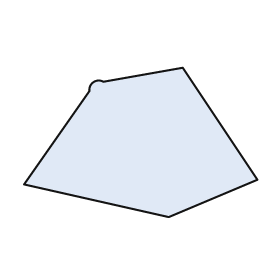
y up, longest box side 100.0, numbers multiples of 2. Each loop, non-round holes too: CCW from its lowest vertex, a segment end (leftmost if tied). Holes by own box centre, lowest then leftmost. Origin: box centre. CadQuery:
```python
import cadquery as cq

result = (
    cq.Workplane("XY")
    .moveTo(12.0, -32.0)
    .lineTo(50.0, -16.0)
    .lineTo(18.0, 32.0)
    .lineTo(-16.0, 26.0)
    .threePointArc((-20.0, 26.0), (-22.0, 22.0))
    .lineTo(-50.0, -18.0)
    .close()
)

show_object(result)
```